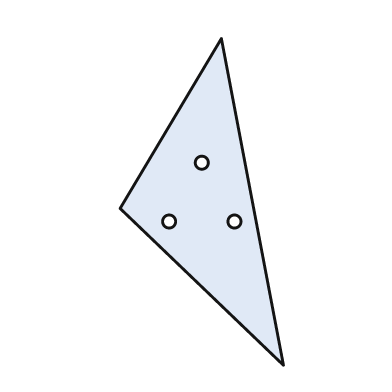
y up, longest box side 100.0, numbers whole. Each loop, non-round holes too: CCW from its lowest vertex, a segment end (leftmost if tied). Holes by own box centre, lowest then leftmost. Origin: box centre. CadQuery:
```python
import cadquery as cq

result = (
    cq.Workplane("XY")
    .moveTo(25.0, -50.0)
    .lineTo(6.0, 50.0)
    .lineTo(-25.0, -2.0)
    .close()
    .moveTo(-10.0, -6.0)
    .circle(2.0)
    .moveTo(10.0, -6.0)
    .circle(2.0)
    .moveTo(0.0, 12.0)
    .circle(2.0)
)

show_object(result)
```